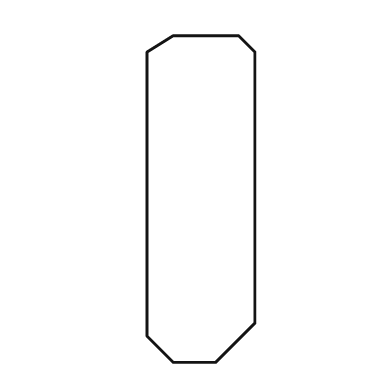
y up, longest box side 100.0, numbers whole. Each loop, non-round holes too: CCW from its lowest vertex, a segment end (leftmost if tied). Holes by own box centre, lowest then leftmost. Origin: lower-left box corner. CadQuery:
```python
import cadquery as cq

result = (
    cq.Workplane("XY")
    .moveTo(8.0, 0.0)
    .lineTo(21.0, 0.0)
    .lineTo(33.0, 12.0)
    .lineTo(33.0, 95.0)
    .lineTo(28.0, 100.0)
    .lineTo(8.0, 100.0)
    .lineTo(0.0, 95.0)
    .lineTo(0.0, 8.0)
    .close()
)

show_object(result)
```